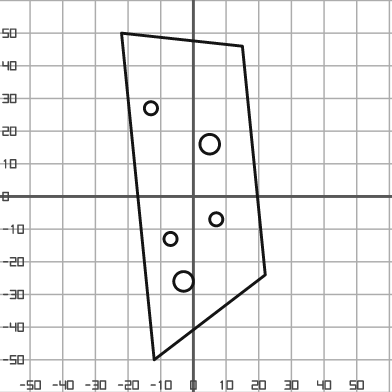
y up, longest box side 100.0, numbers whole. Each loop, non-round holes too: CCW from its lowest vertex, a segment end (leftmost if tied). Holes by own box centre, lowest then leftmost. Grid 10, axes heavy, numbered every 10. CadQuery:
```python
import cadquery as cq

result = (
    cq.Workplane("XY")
    .moveTo(-12.0, -50.0)
    .lineTo(22.0, -24.0)
    .lineTo(15.0, 46.0)
    .lineTo(-22.0, 50.0)
    .close()
    .moveTo(-3.0, -26.0)
    .circle(3.0)
    .moveTo(-7.0, -13.0)
    .circle(2.0)
    .moveTo(7.0, -7.0)
    .circle(2.0)
    .moveTo(5.0, 16.0)
    .circle(3.0)
    .moveTo(-13.0, 27.0)
    .circle(2.0)
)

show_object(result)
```